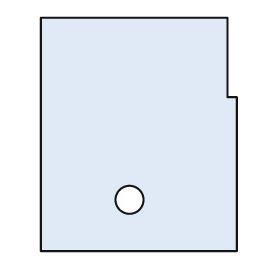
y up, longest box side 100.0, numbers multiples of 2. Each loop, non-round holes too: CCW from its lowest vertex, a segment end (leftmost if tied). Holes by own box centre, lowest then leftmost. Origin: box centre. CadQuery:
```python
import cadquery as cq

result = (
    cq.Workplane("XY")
    .moveTo(-42.0, -50.0)
    .lineTo(42.0, -50.0)
    .lineTo(42.0, 16.0)
    .lineTo(38.0, 16.0)
    .lineTo(38.0, 50.0)
    .lineTo(-42.0, 50.0)
    .close()
    .moveTo(-4.0, -28.0)
    .circle(6.0)
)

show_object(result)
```